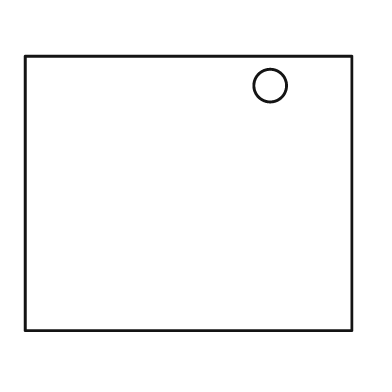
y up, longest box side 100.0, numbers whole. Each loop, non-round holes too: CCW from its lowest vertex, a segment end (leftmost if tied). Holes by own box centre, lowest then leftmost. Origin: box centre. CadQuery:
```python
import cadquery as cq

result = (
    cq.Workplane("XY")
    .moveTo(-50.0, -42.0)
    .lineTo(50.0, -42.0)
    .lineTo(50.0, 42.0)
    .lineTo(-50.0, 42.0)
    .close()
    .moveTo(25.0, 33.0)
    .circle(5.0)
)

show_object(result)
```